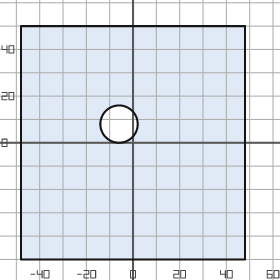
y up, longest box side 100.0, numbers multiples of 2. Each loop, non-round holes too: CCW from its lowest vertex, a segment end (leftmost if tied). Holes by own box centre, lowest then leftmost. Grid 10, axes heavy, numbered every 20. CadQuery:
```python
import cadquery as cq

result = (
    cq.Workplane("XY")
    .moveTo(-48.0, -50.0)
    .lineTo(48.0, -50.0)
    .lineTo(48.0, 50.0)
    .lineTo(-48.0, 50.0)
    .close()
    .moveTo(-6.0, 8.0)
    .circle(8.0)
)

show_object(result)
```